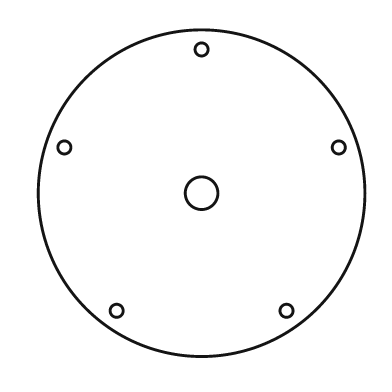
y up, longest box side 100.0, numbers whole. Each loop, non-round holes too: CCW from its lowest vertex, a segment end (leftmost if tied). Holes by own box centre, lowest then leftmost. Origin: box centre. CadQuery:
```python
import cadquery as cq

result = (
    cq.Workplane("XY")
    .moveTo(0.0, 0.0)
    .circle(50.0)
    .moveTo(-26.0, -36.0)
    .circle(2.0)
    .moveTo(26.0, -36.0)
    .circle(2.0)
    .moveTo(0.0, 0.0)
    .circle(5.0)
    .moveTo(-42.0, 14.0)
    .circle(2.0)
    .moveTo(42.0, 14.0)
    .circle(2.0)
    .moveTo(0.0, 44.0)
    .circle(2.0)
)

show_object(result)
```